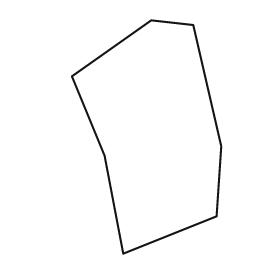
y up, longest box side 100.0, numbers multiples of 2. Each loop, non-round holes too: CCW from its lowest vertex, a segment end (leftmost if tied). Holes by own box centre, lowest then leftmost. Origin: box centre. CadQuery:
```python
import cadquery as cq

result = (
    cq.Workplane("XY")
    .moveTo(-10.0, -50.0)
    .lineTo(30.0, -34.0)
    .lineTo(32.0, -4.0)
    .lineTo(20.0, 48.0)
    .lineTo(2.0, 50.0)
    .lineTo(-32.0, 26.0)
    .lineTo(-18.0, -8.0)
    .close()
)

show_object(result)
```